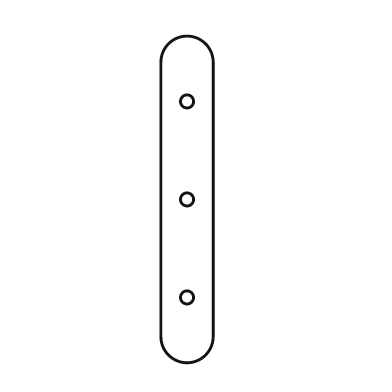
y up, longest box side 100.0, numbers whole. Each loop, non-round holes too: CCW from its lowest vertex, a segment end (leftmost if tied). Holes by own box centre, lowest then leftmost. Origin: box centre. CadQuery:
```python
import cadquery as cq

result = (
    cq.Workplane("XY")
    .moveTo(-8.0, -42.0)
    .threePointArc((0.0, -50.0), (8.0, -42.0))
    .lineTo(8.0, 42.0)
    .threePointArc((0.0, 50.0), (-8.0, 42.0))
    .close()
    .moveTo(0.0, -30.0)
    .circle(2.0)
    .moveTo(0.0, 0.0)
    .circle(2.0)
    .moveTo(0.0, 30.0)
    .circle(2.0)
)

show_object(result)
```